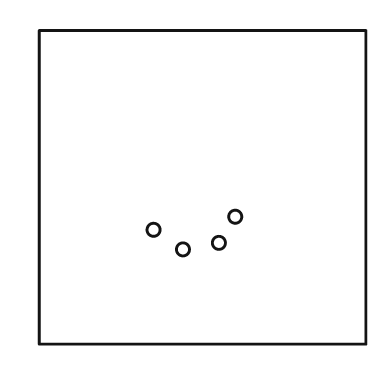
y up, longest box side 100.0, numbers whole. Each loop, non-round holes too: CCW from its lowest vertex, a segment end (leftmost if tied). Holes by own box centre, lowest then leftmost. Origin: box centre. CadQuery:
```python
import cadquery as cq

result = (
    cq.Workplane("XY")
    .moveTo(-50.0, -48.0)
    .lineTo(50.0, -48.0)
    .lineTo(50.0, 48.0)
    .lineTo(-50.0, 48.0)
    .close()
    .moveTo(-6.0, -19.0)
    .circle(2.0)
    .moveTo(5.0, -17.0)
    .circle(2.0)
    .moveTo(-15.0, -13.0)
    .circle(2.0)
    .moveTo(10.0, -9.0)
    .circle(2.0)
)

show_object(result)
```